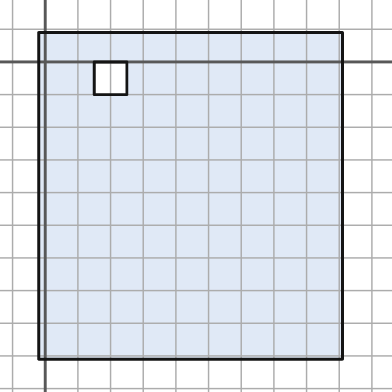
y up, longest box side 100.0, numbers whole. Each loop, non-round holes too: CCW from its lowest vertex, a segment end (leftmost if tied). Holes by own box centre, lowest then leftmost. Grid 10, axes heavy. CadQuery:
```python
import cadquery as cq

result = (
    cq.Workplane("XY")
    .moveTo(-2.0, -91.0)
    .lineTo(91.0, -91.0)
    .lineTo(91.0, 9.0)
    .lineTo(-2.0, 9.0)
    .close()
    .moveTo(15.0, -10.0)
    .lineTo(25.0, -10.0)
    .lineTo(25.0, 0.0)
    .lineTo(15.0, 0.0)
    .close()
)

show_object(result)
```